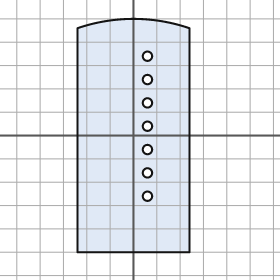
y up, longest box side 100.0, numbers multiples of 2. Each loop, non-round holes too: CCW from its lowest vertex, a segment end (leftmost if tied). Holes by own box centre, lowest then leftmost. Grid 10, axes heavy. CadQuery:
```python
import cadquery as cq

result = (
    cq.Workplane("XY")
    .moveTo(-24.0, -50.0)
    .lineTo(24.0, -50.0)
    .lineTo(24.0, 46.0)
    .threePointArc((0.0, 50.0), (-24.0, 46.0))
    .close()
    .moveTo(6.0, -26.0)
    .circle(2.0)
    .moveTo(6.0, -16.0)
    .circle(2.0)
    .moveTo(6.0, -6.0)
    .circle(2.0)
    .moveTo(6.0, 4.0)
    .circle(2.0)
    .moveTo(6.0, 14.0)
    .circle(2.0)
    .moveTo(6.0, 24.0)
    .circle(2.0)
    .moveTo(6.0, 34.0)
    .circle(2.0)
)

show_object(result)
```